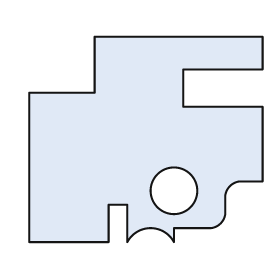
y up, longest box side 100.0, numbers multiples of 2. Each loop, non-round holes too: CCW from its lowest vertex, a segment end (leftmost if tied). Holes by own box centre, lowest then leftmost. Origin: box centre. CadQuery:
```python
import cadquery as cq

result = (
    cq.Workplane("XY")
    .moveTo(-50.0, -44.0)
    .lineTo(-16.0, -44.0)
    .lineTo(-16.0, -28.0)
    .lineTo(-8.0, -28.0)
    .lineTo(-8.0, -44.0)
    .threePointArc((2.0, -38.0), (12.0, -44.0))
    .lineTo(12.0, -38.0)
    .lineTo(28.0, -38.0)
    .threePointArc((32.0, -36.0), (34.0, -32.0))
    .lineTo(34.0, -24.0)
    .threePointArc((36.0, -20.0), (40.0, -18.0))
    .lineTo(50.0, -18.0)
    .lineTo(50.0, 14.0)
    .lineTo(16.0, 14.0)
    .lineTo(16.0, 30.0)
    .lineTo(50.0, 30.0)
    .lineTo(50.0, 44.0)
    .lineTo(-22.0, 44.0)
    .lineTo(-22.0, 20.0)
    .lineTo(-50.0, 20.0)
    .close()
    .moveTo(12.0, -22.0)
    .circle(10.0)
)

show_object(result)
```